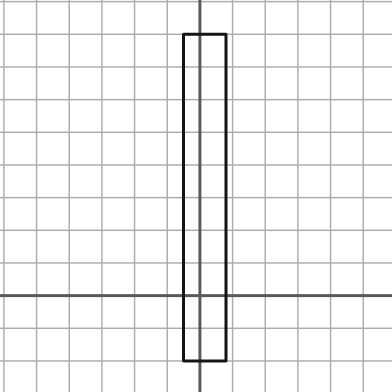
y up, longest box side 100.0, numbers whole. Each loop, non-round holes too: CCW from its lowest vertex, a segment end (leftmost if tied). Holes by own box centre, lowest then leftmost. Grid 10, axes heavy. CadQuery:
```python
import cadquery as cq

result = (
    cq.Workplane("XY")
    .moveTo(-5.0, -20.0)
    .lineTo(8.0, -20.0)
    .lineTo(8.0, 80.0)
    .lineTo(-5.0, 80.0)
    .close()
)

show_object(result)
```